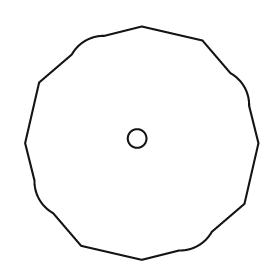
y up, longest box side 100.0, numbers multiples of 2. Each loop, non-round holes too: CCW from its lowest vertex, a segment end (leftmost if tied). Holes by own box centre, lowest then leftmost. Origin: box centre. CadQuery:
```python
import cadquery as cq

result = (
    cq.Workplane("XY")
    .moveTo(0.0, -50.0)
    .lineTo(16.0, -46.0)
    .threePointArc((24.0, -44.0), (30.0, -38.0))
    .lineTo(44.0, -26.0)
    .lineTo(50.0, 0.0)
    .lineTo(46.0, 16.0)
    .threePointArc((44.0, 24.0), (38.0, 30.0))
    .lineTo(26.0, 44.0)
    .lineTo(0.0, 50.0)
    .lineTo(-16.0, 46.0)
    .threePointArc((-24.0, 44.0), (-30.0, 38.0))
    .lineTo(-44.0, 26.0)
    .lineTo(-50.0, 0.0)
    .lineTo(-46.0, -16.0)
    .threePointArc((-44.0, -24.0), (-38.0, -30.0))
    .lineTo(-26.0, -44.0)
    .close()
    .moveTo(-2.0, 2.0)
    .circle(4.0)
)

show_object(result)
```